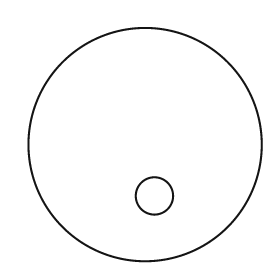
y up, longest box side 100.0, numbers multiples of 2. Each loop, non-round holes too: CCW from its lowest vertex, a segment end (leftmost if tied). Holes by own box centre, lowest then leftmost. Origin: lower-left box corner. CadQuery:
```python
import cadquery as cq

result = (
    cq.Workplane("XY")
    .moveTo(50.0, 50.0)
    .circle(50.0)
    .moveTo(54.0, 28.0)
    .circle(8.0)
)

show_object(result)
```